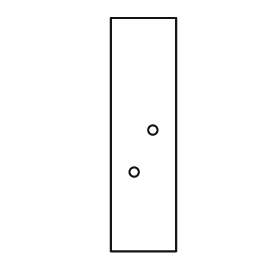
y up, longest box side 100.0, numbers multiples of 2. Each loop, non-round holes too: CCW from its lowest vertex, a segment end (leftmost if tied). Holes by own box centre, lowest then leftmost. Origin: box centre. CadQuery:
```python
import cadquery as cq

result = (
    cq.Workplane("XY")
    .moveTo(-14.0, -50.0)
    .lineTo(14.0, -50.0)
    .lineTo(14.0, 50.0)
    .lineTo(-14.0, 50.0)
    .close()
    .moveTo(-4.0, -16.0)
    .circle(2.0)
    .moveTo(4.0, 2.0)
    .circle(2.0)
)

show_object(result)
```